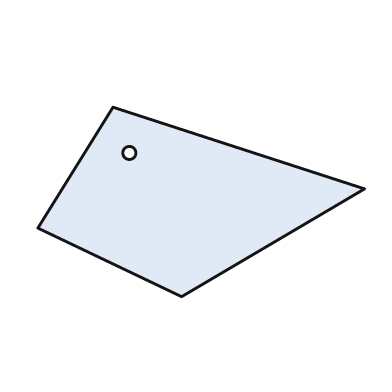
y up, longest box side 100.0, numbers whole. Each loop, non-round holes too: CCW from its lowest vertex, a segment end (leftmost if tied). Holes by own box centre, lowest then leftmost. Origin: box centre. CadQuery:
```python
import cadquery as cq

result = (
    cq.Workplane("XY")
    .moveTo(-6.0, -29.0)
    .lineTo(50.0, 4.0)
    .lineTo(-27.0, 29.0)
    .lineTo(-50.0, -8.0)
    .close()
    .moveTo(-22.0, 15.0)
    .circle(2.0)
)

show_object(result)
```